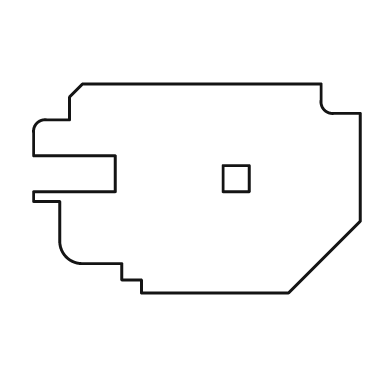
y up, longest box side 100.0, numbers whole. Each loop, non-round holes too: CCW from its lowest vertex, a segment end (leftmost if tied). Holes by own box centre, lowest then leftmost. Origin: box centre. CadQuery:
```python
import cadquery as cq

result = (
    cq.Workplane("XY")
    .moveTo(-17.0, -32.0)
    .lineTo(28.0, -32.0)
    .lineTo(50.0, -10.0)
    .lineTo(50.0, 23.0)
    .lineTo(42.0, 23.0)
    .threePointArc((39.0, 24.0), (38.0, 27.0))
    .lineTo(38.0, 32.0)
    .lineTo(-35.0, 32.0)
    .lineTo(-39.0, 28.0)
    .lineTo(-39.0, 21.0)
    .lineTo(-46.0, 21.0)
    .threePointArc((-49.0, 20.0), (-50.0, 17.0))
    .lineTo(-50.0, 10.0)
    .lineTo(-25.0, 10.0)
    .lineTo(-25.0, -1.0)
    .lineTo(-50.0, -1.0)
    .lineTo(-50.0, -4.0)
    .lineTo(-42.0, -4.0)
    .lineTo(-42.0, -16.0)
    .threePointArc((-40.0, -21.0), (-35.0, -23.0))
    .lineTo(-23.0, -23.0)
    .lineTo(-23.0, -28.0)
    .lineTo(-17.0, -28.0)
    .close()
    .moveTo(8.0, -1.0)
    .lineTo(16.0, -1.0)
    .lineTo(16.0, 7.0)
    .lineTo(8.0, 7.0)
    .close()
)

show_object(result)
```